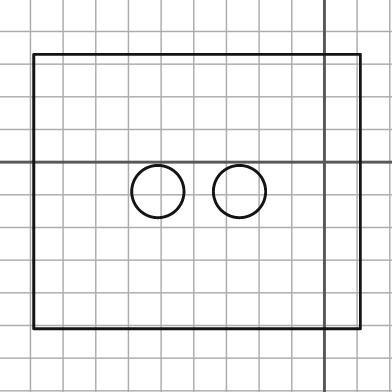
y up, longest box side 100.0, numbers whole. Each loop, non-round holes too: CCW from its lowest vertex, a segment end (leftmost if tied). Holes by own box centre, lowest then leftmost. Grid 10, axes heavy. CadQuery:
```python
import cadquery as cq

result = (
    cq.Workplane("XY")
    .moveTo(-89.0, -51.0)
    .lineTo(11.0, -51.0)
    .lineTo(11.0, 33.0)
    .lineTo(-89.0, 33.0)
    .close()
    .moveTo(-51.0, -9.0)
    .circle(8.0)
    .moveTo(-26.0, -9.0)
    .circle(8.0)
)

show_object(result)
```